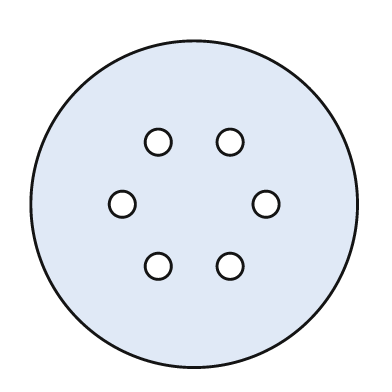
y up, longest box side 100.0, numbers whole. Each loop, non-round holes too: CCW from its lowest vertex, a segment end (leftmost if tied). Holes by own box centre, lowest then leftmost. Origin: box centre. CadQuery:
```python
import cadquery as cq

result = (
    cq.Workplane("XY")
    .moveTo(0.0, 0.0)
    .circle(50.0)
    .moveTo(-11.0, -19.0)
    .circle(4.0)
    .moveTo(11.0, -19.0)
    .circle(4.0)
    .moveTo(-22.0, 0.0)
    .circle(4.0)
    .moveTo(22.0, 0.0)
    .circle(4.0)
    .moveTo(-11.0, 19.0)
    .circle(4.0)
    .moveTo(11.0, 19.0)
    .circle(4.0)
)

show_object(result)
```